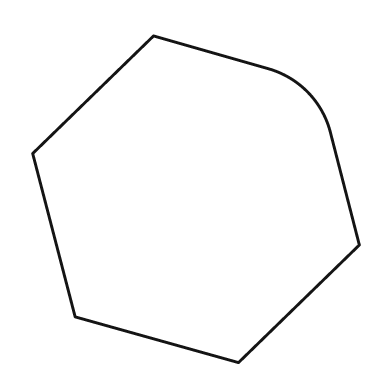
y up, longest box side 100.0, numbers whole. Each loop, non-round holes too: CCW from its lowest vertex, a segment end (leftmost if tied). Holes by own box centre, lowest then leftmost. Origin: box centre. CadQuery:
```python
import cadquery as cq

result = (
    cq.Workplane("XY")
    .moveTo(13.0, -50.0)
    .lineTo(50.0, -14.0)
    .lineTo(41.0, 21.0)
    .threePointArc((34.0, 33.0), (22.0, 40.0))
    .lineTo(-13.0, 50.0)
    .lineTo(-50.0, 14.0)
    .lineTo(-37.0, -36.0)
    .close()
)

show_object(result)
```